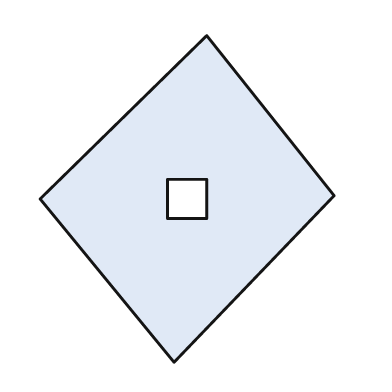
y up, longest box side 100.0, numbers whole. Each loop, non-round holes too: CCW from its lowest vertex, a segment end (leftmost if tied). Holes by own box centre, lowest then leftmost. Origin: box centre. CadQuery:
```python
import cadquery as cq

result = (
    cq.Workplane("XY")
    .moveTo(-4.0, -50.0)
    .lineTo(45.0, 1.0)
    .lineTo(6.0, 50.0)
    .lineTo(-45.0, 0.0)
    .close()
    .moveTo(-6.0, -6.0)
    .lineTo(6.0, -6.0)
    .lineTo(6.0, 6.0)
    .lineTo(-6.0, 6.0)
    .close()
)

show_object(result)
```